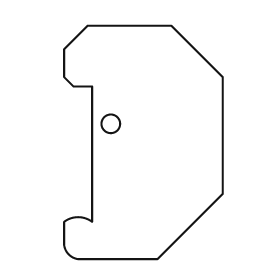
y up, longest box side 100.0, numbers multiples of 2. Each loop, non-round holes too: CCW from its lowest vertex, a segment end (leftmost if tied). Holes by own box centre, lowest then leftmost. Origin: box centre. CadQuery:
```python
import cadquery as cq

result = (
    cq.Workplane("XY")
    .moveTo(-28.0, -50.0)
    .lineTo(6.0, -50.0)
    .lineTo(34.0, -22.0)
    .lineTo(34.0, 28.0)
    .lineTo(12.0, 50.0)
    .lineTo(-24.0, 50.0)
    .lineTo(-34.0, 40.0)
    .lineTo(-34.0, 28.0)
    .lineTo(-30.0, 24.0)
    .lineTo(-22.0, 24.0)
    .lineTo(-22.0, -34.0)
    .threePointArc((-28.0, -32.0), (-34.0, -34.0))
    .lineTo(-34.0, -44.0)
    .threePointArc((-32.0, -48.0), (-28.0, -50.0))
    .close()
    .moveTo(-14.0, 8.0)
    .circle(4.0)
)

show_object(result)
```